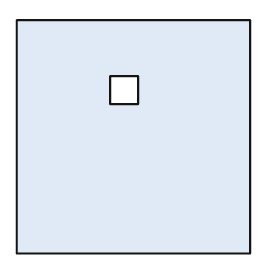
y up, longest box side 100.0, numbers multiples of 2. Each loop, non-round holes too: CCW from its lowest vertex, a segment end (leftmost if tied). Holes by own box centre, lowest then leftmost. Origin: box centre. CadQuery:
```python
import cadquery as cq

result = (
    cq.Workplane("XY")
    .moveTo(-50.0, -50.0)
    .lineTo(50.0, -50.0)
    .lineTo(50.0, 50.0)
    .lineTo(-50.0, 50.0)
    .close()
    .moveTo(-10.0, 14.0)
    .lineTo(2.0, 14.0)
    .lineTo(2.0, 26.0)
    .lineTo(-10.0, 26.0)
    .close()
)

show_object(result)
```